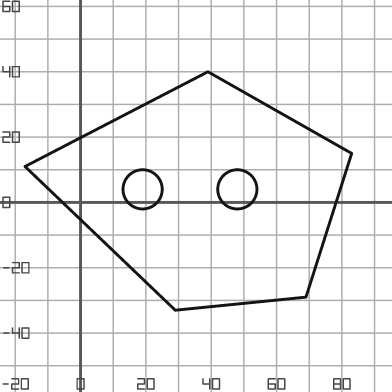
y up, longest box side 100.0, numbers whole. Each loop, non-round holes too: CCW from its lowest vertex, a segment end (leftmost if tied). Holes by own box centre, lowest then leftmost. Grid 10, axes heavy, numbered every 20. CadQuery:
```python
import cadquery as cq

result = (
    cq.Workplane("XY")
    .moveTo(29.0, -33.0)
    .lineTo(69.0, -29.0)
    .lineTo(83.0, 15.0)
    .lineTo(39.0, 40.0)
    .lineTo(-17.0, 11.0)
    .close()
    .moveTo(19.0, 4.0)
    .circle(6.0)
    .moveTo(48.0, 4.0)
    .circle(6.0)
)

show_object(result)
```